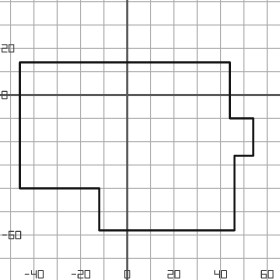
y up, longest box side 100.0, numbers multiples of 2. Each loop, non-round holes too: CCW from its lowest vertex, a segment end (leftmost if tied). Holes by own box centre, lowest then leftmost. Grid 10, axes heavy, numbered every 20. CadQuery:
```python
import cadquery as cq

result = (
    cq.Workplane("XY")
    .moveTo(-12.0, -58.0)
    .lineTo(46.0, -58.0)
    .lineTo(46.0, -26.0)
    .lineTo(54.0, -26.0)
    .lineTo(54.0, -10.0)
    .lineTo(44.0, -10.0)
    .lineTo(44.0, 14.0)
    .lineTo(-46.0, 14.0)
    .lineTo(-46.0, -40.0)
    .lineTo(-12.0, -40.0)
    .close()
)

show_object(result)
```